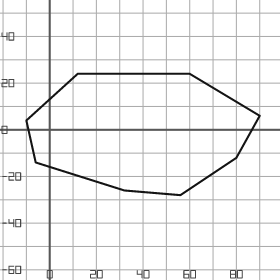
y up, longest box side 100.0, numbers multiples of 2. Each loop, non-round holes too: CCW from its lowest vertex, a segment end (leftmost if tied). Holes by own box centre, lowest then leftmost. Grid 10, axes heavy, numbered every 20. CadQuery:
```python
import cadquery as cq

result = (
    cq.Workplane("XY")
    .moveTo(56.0, -28.0)
    .lineTo(80.0, -12.0)
    .lineTo(90.0, 6.0)
    .lineTo(60.0, 24.0)
    .lineTo(12.0, 24.0)
    .lineTo(-10.0, 4.0)
    .lineTo(-6.0, -14.0)
    .lineTo(32.0, -26.0)
    .close()
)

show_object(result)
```